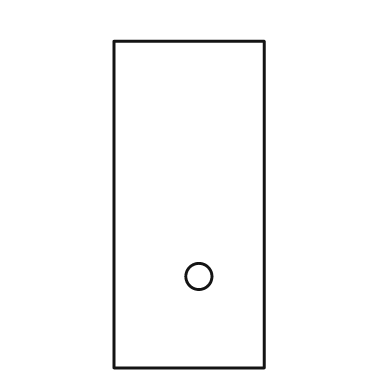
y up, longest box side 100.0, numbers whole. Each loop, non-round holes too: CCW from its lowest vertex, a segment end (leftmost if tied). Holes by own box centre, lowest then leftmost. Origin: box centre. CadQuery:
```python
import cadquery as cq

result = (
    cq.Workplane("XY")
    .moveTo(-23.0, -50.0)
    .lineTo(23.0, -50.0)
    .lineTo(23.0, 50.0)
    .lineTo(-23.0, 50.0)
    .close()
    .moveTo(3.0, -22.0)
    .circle(4.0)
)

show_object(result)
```